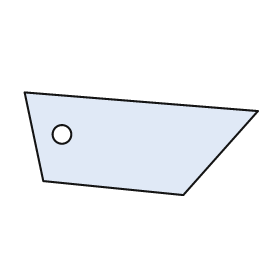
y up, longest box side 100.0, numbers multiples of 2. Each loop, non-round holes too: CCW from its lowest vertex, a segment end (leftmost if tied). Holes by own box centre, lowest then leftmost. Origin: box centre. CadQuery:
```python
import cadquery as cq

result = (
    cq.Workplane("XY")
    .moveTo(18.0, -22.0)
    .lineTo(50.0, 14.0)
    .lineTo(-50.0, 22.0)
    .lineTo(-42.0, -16.0)
    .close()
    .moveTo(-34.0, 4.0)
    .circle(4.0)
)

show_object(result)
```